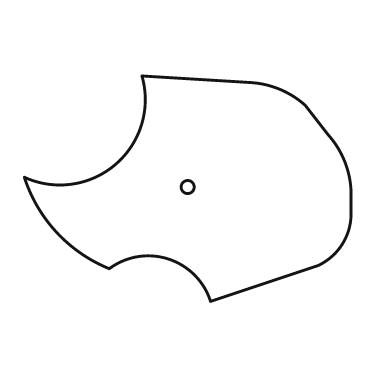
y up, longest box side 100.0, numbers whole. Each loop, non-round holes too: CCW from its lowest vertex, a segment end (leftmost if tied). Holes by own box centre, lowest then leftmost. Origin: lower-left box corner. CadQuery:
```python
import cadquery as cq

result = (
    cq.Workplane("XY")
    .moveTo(57.0, 0.0)
    .lineTo(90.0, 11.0)
    .threePointArc((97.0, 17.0), (100.0, 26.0))
    .lineTo(100.0, 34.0)
    .threePointArc((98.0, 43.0), (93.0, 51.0))
    .lineTo(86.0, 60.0)
    .threePointArc((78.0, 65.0), (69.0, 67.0))
    .lineTo(36.0, 69.0)
    .threePointArc((28.0, 42.0), (0.0, 38.0))
    .threePointArc((10.0, 21.0), (26.0, 10.0))
    .threePointArc((44.0, 13.0), (57.0, 0.0))
    .close()
    .moveTo(50.0, 35.0)
    .circle(2.0)
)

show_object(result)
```